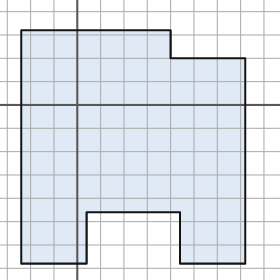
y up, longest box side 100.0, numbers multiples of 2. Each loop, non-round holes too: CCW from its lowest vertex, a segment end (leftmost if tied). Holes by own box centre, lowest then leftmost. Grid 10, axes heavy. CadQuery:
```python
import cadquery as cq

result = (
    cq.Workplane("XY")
    .moveTo(-24.0, -68.0)
    .lineTo(4.0, -68.0)
    .lineTo(4.0, -46.0)
    .lineTo(44.0, -46.0)
    .lineTo(44.0, -68.0)
    .lineTo(72.0, -68.0)
    .lineTo(72.0, 20.0)
    .lineTo(40.0, 20.0)
    .lineTo(40.0, 32.0)
    .lineTo(-24.0, 32.0)
    .close()
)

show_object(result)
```